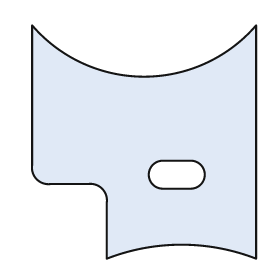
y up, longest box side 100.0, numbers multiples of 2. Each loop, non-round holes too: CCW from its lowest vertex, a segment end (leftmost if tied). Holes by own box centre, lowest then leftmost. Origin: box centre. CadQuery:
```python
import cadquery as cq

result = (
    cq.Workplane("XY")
    .moveTo(-16.0, -50.0)
    .threePointArc((16.0, -44.0), (48.0, -50.0))
    .lineTo(48.0, 50.0)
    .threePointArc((0.0, 28.0), (-48.0, 50.0))
    .lineTo(-48.0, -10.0)
    .threePointArc((-46.0, -16.0), (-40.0, -18.0))
    .lineTo(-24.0, -18.0)
    .threePointArc((-18.0, -20.0), (-16.0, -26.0))
    .close()
    .moveTo(8.0, -20.0)
    .lineTo(20.0, -20.0)
    .threePointArc((26.0, -14.0), (20.0, -8.0))
    .lineTo(8.0, -8.0)
    .threePointArc((2.0, -14.0), (8.0, -20.0))
    .close()
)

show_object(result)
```